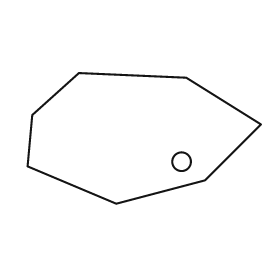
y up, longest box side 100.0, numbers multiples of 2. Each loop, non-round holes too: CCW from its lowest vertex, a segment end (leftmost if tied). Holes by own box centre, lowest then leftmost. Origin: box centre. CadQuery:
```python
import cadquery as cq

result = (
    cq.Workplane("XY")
    .moveTo(-12.0, -28.0)
    .lineTo(26.0, -18.0)
    .lineTo(50.0, 6.0)
    .lineTo(18.0, 26.0)
    .lineTo(-28.0, 28.0)
    .lineTo(-48.0, 10.0)
    .lineTo(-50.0, -12.0)
    .close()
    .moveTo(16.0, -10.0)
    .circle(4.0)
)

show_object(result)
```